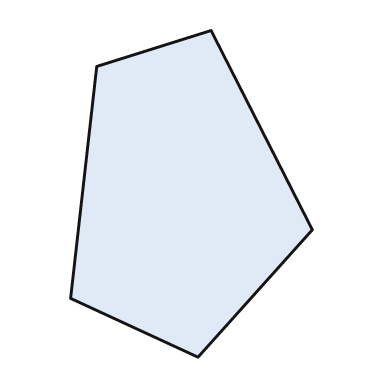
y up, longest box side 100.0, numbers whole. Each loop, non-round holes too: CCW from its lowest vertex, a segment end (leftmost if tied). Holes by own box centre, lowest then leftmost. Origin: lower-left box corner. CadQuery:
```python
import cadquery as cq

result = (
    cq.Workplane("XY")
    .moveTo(39.0, 0.0)
    .lineTo(74.0, 39.0)
    .lineTo(43.0, 100.0)
    .lineTo(8.0, 89.0)
    .lineTo(0.0, 18.0)
    .close()
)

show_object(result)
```